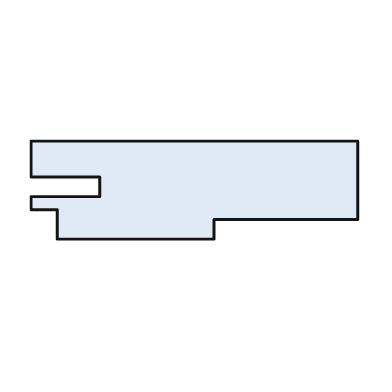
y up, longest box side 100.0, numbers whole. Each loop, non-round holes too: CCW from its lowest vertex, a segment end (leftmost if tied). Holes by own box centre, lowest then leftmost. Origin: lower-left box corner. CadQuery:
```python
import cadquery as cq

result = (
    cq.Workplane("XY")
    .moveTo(8.0, 0.0)
    .lineTo(56.0, 0.0)
    .lineTo(56.0, 6.0)
    .lineTo(100.0, 6.0)
    .lineTo(100.0, 30.0)
    .lineTo(0.0, 30.0)
    .lineTo(0.0, 19.0)
    .lineTo(21.0, 19.0)
    .lineTo(21.0, 13.0)
    .lineTo(0.0, 13.0)
    .lineTo(0.0, 9.0)
    .lineTo(8.0, 9.0)
    .close()
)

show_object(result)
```